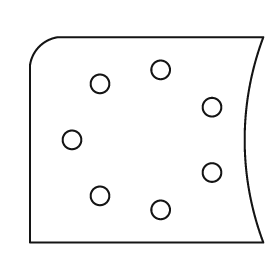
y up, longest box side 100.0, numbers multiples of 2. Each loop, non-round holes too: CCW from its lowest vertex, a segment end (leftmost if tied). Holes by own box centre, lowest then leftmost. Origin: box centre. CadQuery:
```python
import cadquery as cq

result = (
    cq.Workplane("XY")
    .moveTo(-50.0, -44.0)
    .lineTo(50.0, -44.0)
    .threePointArc((42.0, 0.0), (50.0, 44.0))
    .lineTo(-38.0, 44.0)
    .threePointArc((-46.0, 40.0), (-50.0, 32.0))
    .close()
    .moveTo(6.0, -30.0)
    .circle(4.0)
    .moveTo(-20.0, -24.0)
    .circle(4.0)
    .moveTo(28.0, -14.0)
    .circle(4.0)
    .moveTo(-32.0, 0.0)
    .circle(4.0)
    .moveTo(28.0, 14.0)
    .circle(4.0)
    .moveTo(-20.0, 24.0)
    .circle(4.0)
    .moveTo(6.0, 30.0)
    .circle(4.0)
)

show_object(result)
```